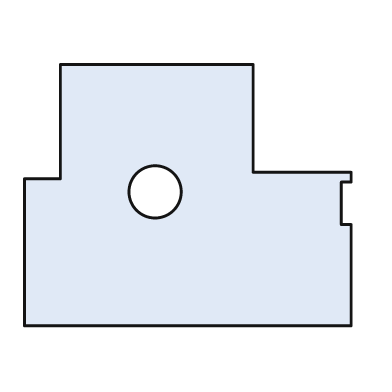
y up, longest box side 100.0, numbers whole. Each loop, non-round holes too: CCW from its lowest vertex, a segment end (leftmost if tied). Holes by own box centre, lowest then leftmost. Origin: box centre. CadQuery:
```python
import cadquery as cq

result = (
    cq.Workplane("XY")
    .moveTo(-50.0, -40.0)
    .lineTo(50.0, -40.0)
    .lineTo(50.0, -9.0)
    .lineTo(47.0, -9.0)
    .lineTo(47.0, 4.0)
    .lineTo(50.0, 4.0)
    .lineTo(50.0, 7.0)
    .lineTo(20.0, 7.0)
    .lineTo(20.0, 40.0)
    .lineTo(-39.0, 40.0)
    .lineTo(-39.0, 5.0)
    .lineTo(-50.0, 5.0)
    .close()
    .moveTo(-10.0, 1.0)
    .circle(8.0)
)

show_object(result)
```